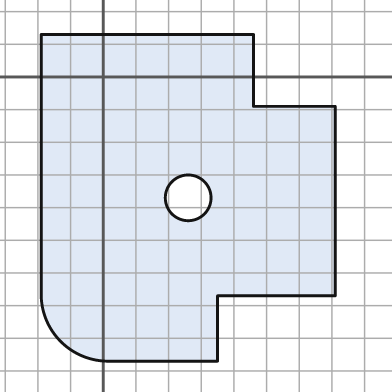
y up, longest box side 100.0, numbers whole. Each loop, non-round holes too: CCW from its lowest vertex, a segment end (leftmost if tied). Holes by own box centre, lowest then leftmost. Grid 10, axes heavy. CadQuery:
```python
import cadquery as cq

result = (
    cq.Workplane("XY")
    .moveTo(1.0, -87.0)
    .lineTo(35.0, -87.0)
    .lineTo(35.0, -67.0)
    .lineTo(71.0, -67.0)
    .lineTo(71.0, -9.0)
    .lineTo(46.0, -9.0)
    .lineTo(46.0, 13.0)
    .lineTo(-19.0, 13.0)
    .lineTo(-19.0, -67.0)
    .threePointArc((-13.0, -81.0), (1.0, -87.0))
    .close()
    .moveTo(26.0, -37.0)
    .circle(7.0)
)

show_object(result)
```